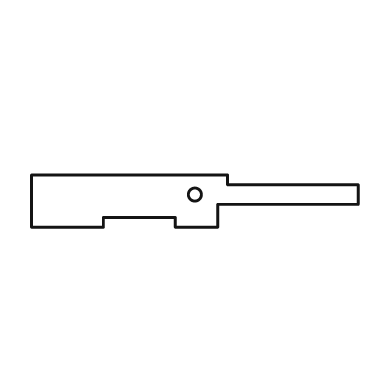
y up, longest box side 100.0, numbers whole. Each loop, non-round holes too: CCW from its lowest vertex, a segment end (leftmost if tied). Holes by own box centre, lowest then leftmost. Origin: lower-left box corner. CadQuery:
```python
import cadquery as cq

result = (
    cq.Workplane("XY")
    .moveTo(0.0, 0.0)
    .lineTo(22.0, 0.0)
    .lineTo(22.0, 3.0)
    .lineTo(44.0, 3.0)
    .lineTo(44.0, 0.0)
    .lineTo(57.0, 0.0)
    .lineTo(57.0, 7.0)
    .lineTo(100.0, 7.0)
    .lineTo(100.0, 13.0)
    .lineTo(60.0, 13.0)
    .lineTo(60.0, 16.0)
    .lineTo(0.0, 16.0)
    .close()
    .moveTo(50.0, 10.0)
    .circle(2.0)
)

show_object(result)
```